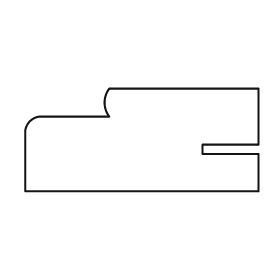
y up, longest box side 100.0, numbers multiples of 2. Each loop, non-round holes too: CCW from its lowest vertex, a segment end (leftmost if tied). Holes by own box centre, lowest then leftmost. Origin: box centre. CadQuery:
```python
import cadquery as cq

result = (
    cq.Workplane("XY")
    .moveTo(-50.0, -22.0)
    .lineTo(50.0, -22.0)
    .lineTo(50.0, -6.0)
    .lineTo(26.0, -6.0)
    .lineTo(26.0, -2.0)
    .lineTo(50.0, -2.0)
    .lineTo(50.0, 22.0)
    .lineTo(-14.0, 22.0)
    .threePointArc((-16.0, 16.0), (-14.0, 10.0))
    .lineTo(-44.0, 10.0)
    .threePointArc((-48.0, 8.0), (-50.0, 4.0))
    .close()
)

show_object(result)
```